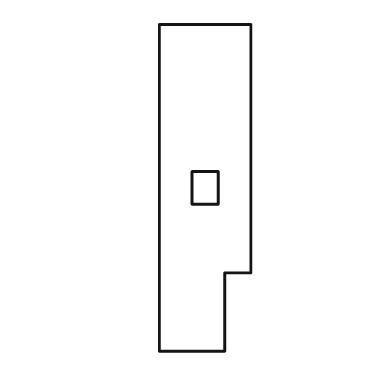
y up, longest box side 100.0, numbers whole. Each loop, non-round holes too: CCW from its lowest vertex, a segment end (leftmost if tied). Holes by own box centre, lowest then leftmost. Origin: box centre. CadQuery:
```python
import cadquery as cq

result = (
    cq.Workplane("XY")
    .moveTo(-14.0, -50.0)
    .lineTo(6.0, -50.0)
    .lineTo(6.0, -26.0)
    .lineTo(14.0, -26.0)
    .lineTo(14.0, 50.0)
    .lineTo(-14.0, 50.0)
    .close()
    .moveTo(-4.0, -5.0)
    .lineTo(4.0, -5.0)
    .lineTo(4.0, 5.0)
    .lineTo(-4.0, 5.0)
    .close()
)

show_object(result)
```